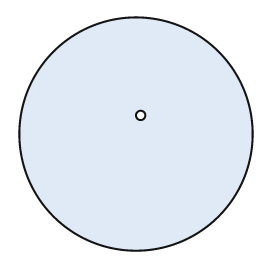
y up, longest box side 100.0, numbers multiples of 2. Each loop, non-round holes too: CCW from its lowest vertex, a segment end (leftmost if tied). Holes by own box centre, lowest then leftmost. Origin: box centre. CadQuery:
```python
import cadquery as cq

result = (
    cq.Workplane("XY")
    .moveTo(0.0, 0.0)
    .circle(50.0)
    .moveTo(2.0, 8.0)
    .circle(2.0)
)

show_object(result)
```